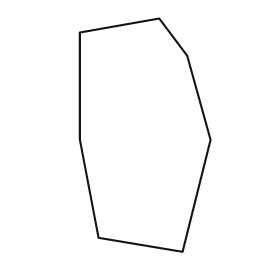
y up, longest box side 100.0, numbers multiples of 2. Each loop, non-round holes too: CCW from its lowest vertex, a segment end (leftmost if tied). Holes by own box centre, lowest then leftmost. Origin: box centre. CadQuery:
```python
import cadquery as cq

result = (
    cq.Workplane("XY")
    .moveTo(16.0, -50.0)
    .lineTo(28.0, -2.0)
    .lineTo(18.0, 34.0)
    .lineTo(6.0, 50.0)
    .lineTo(-28.0, 44.0)
    .lineTo(-28.0, -2.0)
    .lineTo(-20.0, -44.0)
    .close()
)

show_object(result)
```